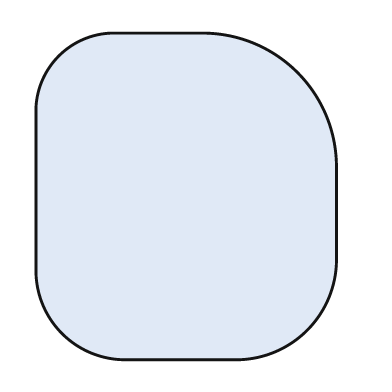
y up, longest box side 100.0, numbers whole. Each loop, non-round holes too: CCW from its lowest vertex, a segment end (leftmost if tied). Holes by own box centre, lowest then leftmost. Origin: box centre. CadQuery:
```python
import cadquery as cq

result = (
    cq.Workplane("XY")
    .moveTo(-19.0, -50.0)
    .lineTo(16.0, -50.0)
    .threePointArc((37.0, -41.0), (46.0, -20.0))
    .lineTo(46.0, 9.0)
    .threePointArc((34.0, 38.0), (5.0, 50.0))
    .lineTo(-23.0, 50.0)
    .threePointArc((-39.0, 43.0), (-46.0, 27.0))
    .lineTo(-46.0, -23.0)
    .threePointArc((-38.0, -42.0), (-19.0, -50.0))
    .close()
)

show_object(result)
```